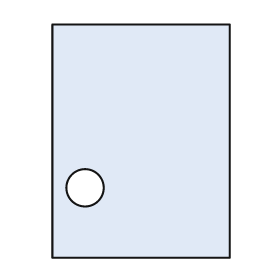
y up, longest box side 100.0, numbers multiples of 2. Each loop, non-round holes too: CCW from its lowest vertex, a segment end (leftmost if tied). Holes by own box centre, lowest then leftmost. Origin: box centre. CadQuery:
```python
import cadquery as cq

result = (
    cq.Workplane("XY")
    .moveTo(-38.0, -50.0)
    .lineTo(38.0, -50.0)
    .lineTo(38.0, 50.0)
    .lineTo(-38.0, 50.0)
    .close()
    .moveTo(-24.0, -20.0)
    .circle(8.0)
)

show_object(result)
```